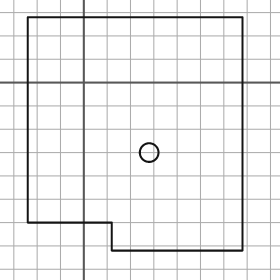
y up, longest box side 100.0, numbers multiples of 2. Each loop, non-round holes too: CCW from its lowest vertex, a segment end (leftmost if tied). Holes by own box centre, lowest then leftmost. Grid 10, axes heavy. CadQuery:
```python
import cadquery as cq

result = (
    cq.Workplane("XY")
    .moveTo(12.0, -72.0)
    .lineTo(68.0, -72.0)
    .lineTo(68.0, 28.0)
    .lineTo(-24.0, 28.0)
    .lineTo(-24.0, -60.0)
    .lineTo(12.0, -60.0)
    .close()
    .moveTo(28.0, -30.0)
    .circle(4.0)
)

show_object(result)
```